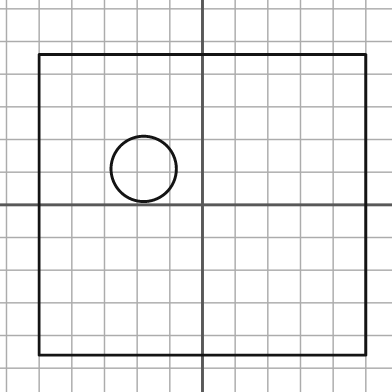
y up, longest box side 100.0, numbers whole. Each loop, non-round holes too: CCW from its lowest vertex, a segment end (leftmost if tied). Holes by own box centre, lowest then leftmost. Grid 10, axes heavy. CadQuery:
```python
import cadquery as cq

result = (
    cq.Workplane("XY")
    .moveTo(-50.0, -46.0)
    .lineTo(50.0, -46.0)
    .lineTo(50.0, 46.0)
    .lineTo(-50.0, 46.0)
    .close()
    .moveTo(-18.0, 11.0)
    .circle(10.0)
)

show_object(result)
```